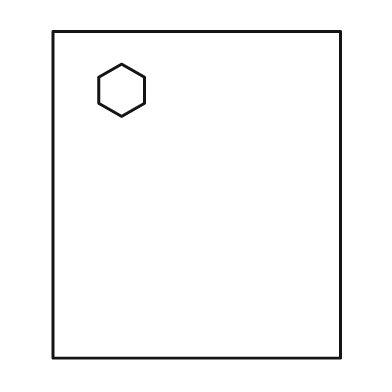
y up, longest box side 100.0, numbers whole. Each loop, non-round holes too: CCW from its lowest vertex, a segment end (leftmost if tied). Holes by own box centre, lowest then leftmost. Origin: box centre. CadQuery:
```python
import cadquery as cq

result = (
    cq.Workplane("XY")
    .moveTo(-44.0, -50.0)
    .lineTo(44.0, -50.0)
    .lineTo(44.0, 50.0)
    .lineTo(-44.0, 50.0)
    .close()
    .moveTo(-23.0, 24.0)
    .lineTo(-16.0, 28.0)
    .lineTo(-16.0, 36.0)
    .lineTo(-23.0, 40.0)
    .lineTo(-30.0, 36.0)
    .lineTo(-30.0, 28.0)
    .close()
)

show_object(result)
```